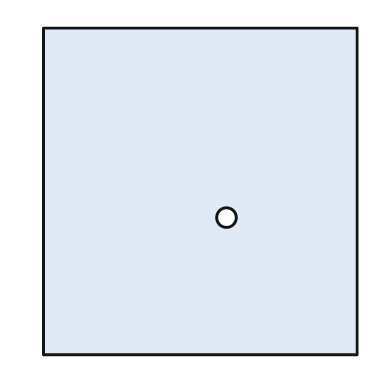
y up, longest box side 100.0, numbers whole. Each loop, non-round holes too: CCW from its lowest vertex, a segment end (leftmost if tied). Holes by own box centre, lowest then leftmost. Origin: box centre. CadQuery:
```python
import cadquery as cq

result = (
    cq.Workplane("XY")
    .moveTo(-48.0, -50.0)
    .lineTo(48.0, -50.0)
    .lineTo(48.0, 50.0)
    .lineTo(-48.0, 50.0)
    .close()
    .moveTo(8.0, -8.0)
    .circle(3.0)
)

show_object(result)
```